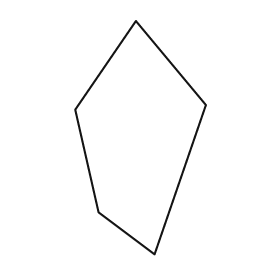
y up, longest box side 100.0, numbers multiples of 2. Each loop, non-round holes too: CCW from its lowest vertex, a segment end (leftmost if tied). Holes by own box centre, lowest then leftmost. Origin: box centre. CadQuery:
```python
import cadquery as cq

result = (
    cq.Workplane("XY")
    .moveTo(6.0, -50.0)
    .lineTo(28.0, 14.0)
    .lineTo(-2.0, 50.0)
    .lineTo(-28.0, 12.0)
    .lineTo(-18.0, -32.0)
    .close()
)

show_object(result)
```